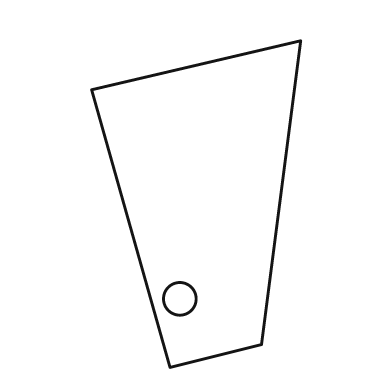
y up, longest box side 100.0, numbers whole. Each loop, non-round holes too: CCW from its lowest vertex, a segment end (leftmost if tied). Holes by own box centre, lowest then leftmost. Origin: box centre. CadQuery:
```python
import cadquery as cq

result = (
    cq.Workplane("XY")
    .moveTo(-8.0, -50.0)
    .lineTo(20.0, -43.0)
    .lineTo(32.0, 50.0)
    .lineTo(-32.0, 35.0)
    .close()
    .moveTo(-5.0, -29.0)
    .circle(5.0)
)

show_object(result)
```